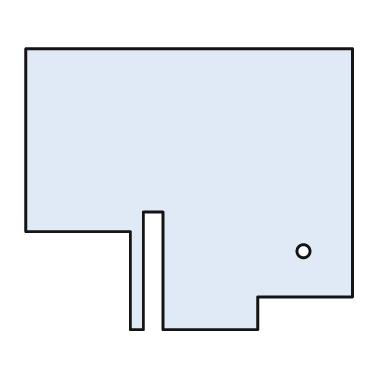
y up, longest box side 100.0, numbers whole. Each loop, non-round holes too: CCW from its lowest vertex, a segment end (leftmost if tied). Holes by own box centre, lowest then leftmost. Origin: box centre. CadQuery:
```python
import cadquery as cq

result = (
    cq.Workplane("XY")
    .moveTo(-18.0, -43.0)
    .lineTo(-14.0, -43.0)
    .lineTo(-14.0, -7.0)
    .lineTo(-8.0, -7.0)
    .lineTo(-8.0, -43.0)
    .lineTo(21.0, -43.0)
    .lineTo(21.0, -33.0)
    .lineTo(50.0, -33.0)
    .lineTo(50.0, 43.0)
    .lineTo(-50.0, 43.0)
    .lineTo(-50.0, -13.0)
    .lineTo(-18.0, -13.0)
    .close()
    .moveTo(35.0, -19.0)
    .circle(2.0)
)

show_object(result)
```